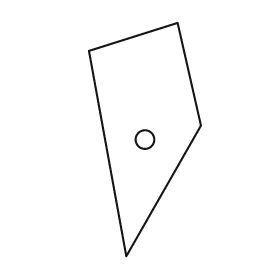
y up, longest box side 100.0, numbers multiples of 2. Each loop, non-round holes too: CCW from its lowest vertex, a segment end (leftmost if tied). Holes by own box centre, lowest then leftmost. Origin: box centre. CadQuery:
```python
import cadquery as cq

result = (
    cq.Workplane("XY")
    .moveTo(-8.0, -50.0)
    .lineTo(24.0, 6.0)
    .lineTo(14.0, 50.0)
    .lineTo(-24.0, 38.0)
    .close()
    .moveTo(0.0, 0.0)
    .circle(4.0)
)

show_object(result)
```